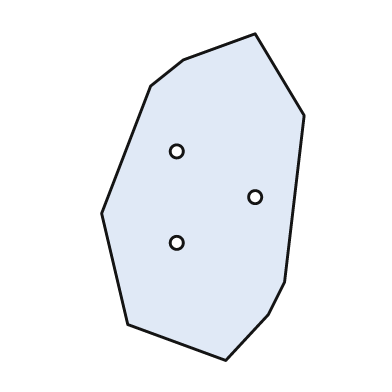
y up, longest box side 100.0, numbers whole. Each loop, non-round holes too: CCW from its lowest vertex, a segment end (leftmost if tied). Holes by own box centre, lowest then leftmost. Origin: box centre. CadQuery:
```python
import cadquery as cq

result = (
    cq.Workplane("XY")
    .moveTo(7.0, -50.0)
    .lineTo(20.0, -36.0)
    .lineTo(25.0, -26.0)
    .lineTo(31.0, 25.0)
    .lineTo(16.0, 50.0)
    .lineTo(-6.0, 42.0)
    .lineTo(-16.0, 34.0)
    .lineTo(-31.0, -5.0)
    .lineTo(-23.0, -39.0)
    .close()
    .moveTo(-8.0, -14.0)
    .circle(2.0)
    .moveTo(16.0, 0.0)
    .circle(2.0)
    .moveTo(-8.0, 14.0)
    .circle(2.0)
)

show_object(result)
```